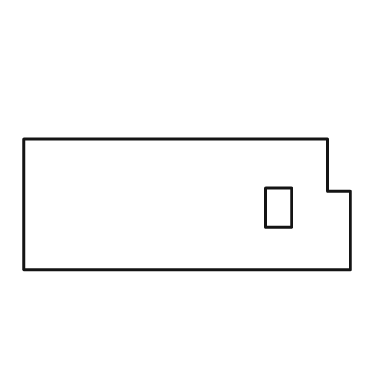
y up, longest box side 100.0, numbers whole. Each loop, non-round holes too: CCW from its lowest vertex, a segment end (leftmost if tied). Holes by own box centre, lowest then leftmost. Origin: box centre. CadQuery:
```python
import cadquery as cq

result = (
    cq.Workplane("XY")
    .moveTo(-50.0, -20.0)
    .lineTo(50.0, -20.0)
    .lineTo(50.0, 4.0)
    .lineTo(43.0, 4.0)
    .lineTo(43.0, 20.0)
    .lineTo(-50.0, 20.0)
    .close()
    .moveTo(24.0, -7.0)
    .lineTo(32.0, -7.0)
    .lineTo(32.0, 5.0)
    .lineTo(24.0, 5.0)
    .close()
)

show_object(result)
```